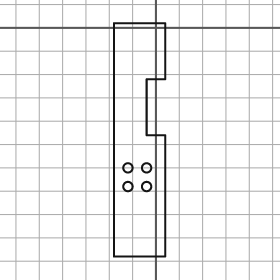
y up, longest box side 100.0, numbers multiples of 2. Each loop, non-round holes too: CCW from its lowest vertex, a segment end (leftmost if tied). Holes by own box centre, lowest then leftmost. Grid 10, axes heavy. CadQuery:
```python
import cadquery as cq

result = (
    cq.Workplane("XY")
    .moveTo(-18.0, -98.0)
    .lineTo(4.0, -98.0)
    .lineTo(4.0, -46.0)
    .lineTo(-4.0, -46.0)
    .lineTo(-4.0, -22.0)
    .lineTo(4.0, -22.0)
    .lineTo(4.0, 2.0)
    .lineTo(-18.0, 2.0)
    .close()
    .moveTo(-12.0, -68.0)
    .circle(2.0)
    .moveTo(-4.0, -68.0)
    .circle(2.0)
    .moveTo(-12.0, -60.0)
    .circle(2.0)
    .moveTo(-4.0, -60.0)
    .circle(2.0)
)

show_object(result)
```